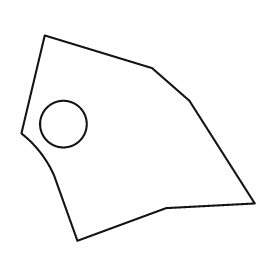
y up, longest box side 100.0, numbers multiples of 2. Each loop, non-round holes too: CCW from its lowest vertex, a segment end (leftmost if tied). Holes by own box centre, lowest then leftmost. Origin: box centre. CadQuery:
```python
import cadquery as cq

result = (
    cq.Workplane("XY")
    .moveTo(-26.0, -44.0)
    .lineTo(12.0, -30.0)
    .lineTo(50.0, -28.0)
    .lineTo(22.0, 16.0)
    .lineTo(6.0, 30.0)
    .lineTo(-40.0, 44.0)
    .lineTo(-50.0, 2.0)
    .threePointArc((-42.0, -6.0), (-36.0, -16.0))
    .close()
    .moveTo(-32.0, 6.0)
    .circle(10.0)
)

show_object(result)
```